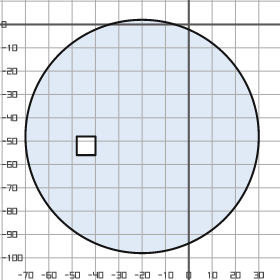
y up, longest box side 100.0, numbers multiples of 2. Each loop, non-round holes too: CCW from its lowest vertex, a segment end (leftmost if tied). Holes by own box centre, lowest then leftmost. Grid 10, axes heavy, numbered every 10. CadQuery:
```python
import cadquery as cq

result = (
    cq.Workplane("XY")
    .moveTo(-20.0, -48.0)
    .circle(50.0)
    .moveTo(-48.0, -56.0)
    .lineTo(-40.0, -56.0)
    .lineTo(-40.0, -48.0)
    .lineTo(-48.0, -48.0)
    .close()
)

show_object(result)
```